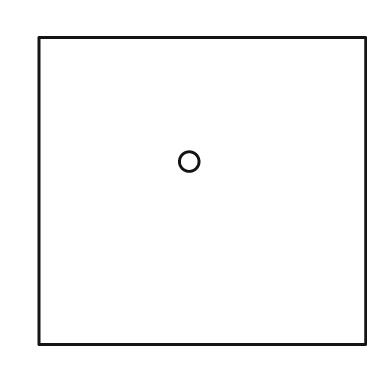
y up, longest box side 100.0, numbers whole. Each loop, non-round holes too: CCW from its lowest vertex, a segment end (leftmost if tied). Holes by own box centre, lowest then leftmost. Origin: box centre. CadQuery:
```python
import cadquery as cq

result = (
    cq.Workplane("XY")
    .moveTo(-50.0, -47.0)
    .lineTo(50.0, -47.0)
    .lineTo(50.0, 47.0)
    .lineTo(-50.0, 47.0)
    .close()
    .moveTo(-4.0, 9.0)
    .circle(3.0)
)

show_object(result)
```